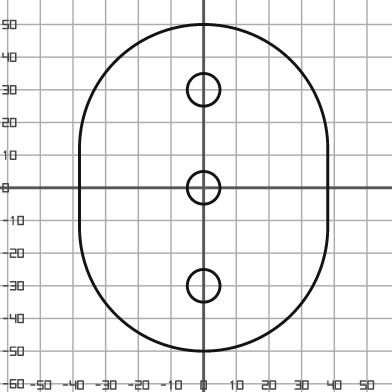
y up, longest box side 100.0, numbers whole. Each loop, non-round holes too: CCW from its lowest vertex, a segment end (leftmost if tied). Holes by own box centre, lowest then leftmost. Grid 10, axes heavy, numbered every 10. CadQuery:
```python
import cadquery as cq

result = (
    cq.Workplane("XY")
    .moveTo(-38.0, -12.0)
    .threePointArc((0.0, -50.0), (38.0, -12.0))
    .lineTo(38.0, 12.0)
    .threePointArc((0.0, 50.0), (-38.0, 12.0))
    .close()
    .moveTo(0.0, -30.0)
    .circle(5.0)
    .moveTo(0.0, 0.0)
    .circle(5.0)
    .moveTo(0.0, 30.0)
    .circle(5.0)
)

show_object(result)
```